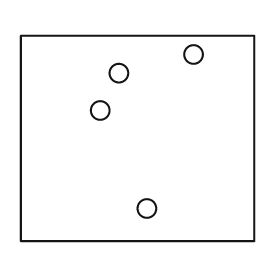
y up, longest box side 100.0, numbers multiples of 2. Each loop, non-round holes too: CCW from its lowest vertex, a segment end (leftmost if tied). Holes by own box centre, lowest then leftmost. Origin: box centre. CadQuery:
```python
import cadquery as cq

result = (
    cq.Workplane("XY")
    .moveTo(-50.0, -44.0)
    .lineTo(50.0, -44.0)
    .lineTo(50.0, 44.0)
    .lineTo(-50.0, 44.0)
    .close()
    .moveTo(4.0, -30.0)
    .circle(4.0)
    .moveTo(-16.0, 12.0)
    .circle(4.0)
    .moveTo(-8.0, 28.0)
    .circle(4.0)
    .moveTo(24.0, 36.0)
    .circle(4.0)
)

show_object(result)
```